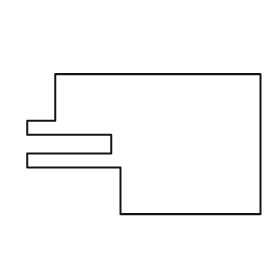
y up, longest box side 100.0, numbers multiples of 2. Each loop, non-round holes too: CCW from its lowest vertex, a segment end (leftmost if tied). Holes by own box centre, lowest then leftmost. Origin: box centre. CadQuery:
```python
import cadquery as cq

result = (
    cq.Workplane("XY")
    .moveTo(-10.0, -30.0)
    .lineTo(50.0, -30.0)
    .lineTo(50.0, 30.0)
    .lineTo(-38.0, 30.0)
    .lineTo(-38.0, 10.0)
    .lineTo(-50.0, 10.0)
    .lineTo(-50.0, 4.0)
    .lineTo(-14.0, 4.0)
    .lineTo(-14.0, -4.0)
    .lineTo(-50.0, -4.0)
    .lineTo(-50.0, -10.0)
    .lineTo(-10.0, -10.0)
    .close()
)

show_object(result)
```